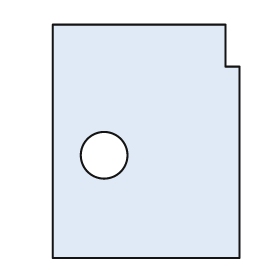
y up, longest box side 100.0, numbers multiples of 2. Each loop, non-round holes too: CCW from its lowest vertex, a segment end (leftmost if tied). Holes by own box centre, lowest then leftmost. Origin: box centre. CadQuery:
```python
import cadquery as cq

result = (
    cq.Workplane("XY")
    .moveTo(-40.0, -50.0)
    .lineTo(40.0, -50.0)
    .lineTo(40.0, 32.0)
    .lineTo(34.0, 32.0)
    .lineTo(34.0, 50.0)
    .lineTo(-40.0, 50.0)
    .close()
    .moveTo(-18.0, -6.0)
    .circle(10.0)
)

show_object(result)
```